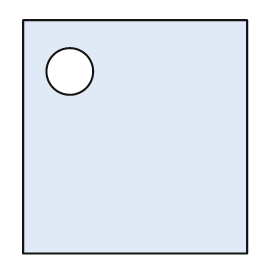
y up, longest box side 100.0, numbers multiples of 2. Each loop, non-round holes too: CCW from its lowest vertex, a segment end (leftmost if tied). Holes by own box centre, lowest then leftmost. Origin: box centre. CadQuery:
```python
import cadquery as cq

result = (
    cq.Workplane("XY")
    .moveTo(-48.0, -50.0)
    .lineTo(48.0, -50.0)
    .lineTo(48.0, 50.0)
    .lineTo(-48.0, 50.0)
    .close()
    .moveTo(-28.0, 28.0)
    .circle(10.0)
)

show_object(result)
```